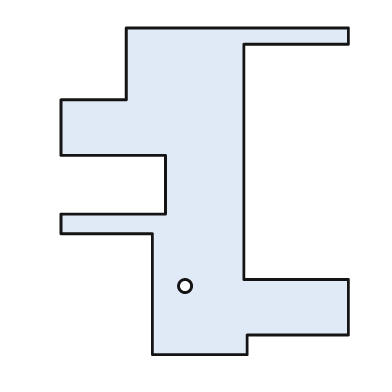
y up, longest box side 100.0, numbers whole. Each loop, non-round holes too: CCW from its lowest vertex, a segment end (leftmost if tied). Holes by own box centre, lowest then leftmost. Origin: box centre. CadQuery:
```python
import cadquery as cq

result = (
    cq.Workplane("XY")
    .moveTo(-16.0, -50.0)
    .lineTo(13.0, -50.0)
    .lineTo(13.0, -44.0)
    .lineTo(44.0, -44.0)
    .lineTo(44.0, -27.0)
    .lineTo(12.0, -27.0)
    .lineTo(12.0, 45.0)
    .lineTo(44.0, 45.0)
    .lineTo(44.0, 50.0)
    .lineTo(-24.0, 50.0)
    .lineTo(-24.0, 28.0)
    .lineTo(-44.0, 28.0)
    .lineTo(-44.0, 11.0)
    .lineTo(-12.0, 11.0)
    .lineTo(-12.0, -7.0)
    .lineTo(-44.0, -7.0)
    .lineTo(-44.0, -13.0)
    .lineTo(-16.0, -13.0)
    .close()
    .moveTo(-6.0, -29.0)
    .circle(2.0)
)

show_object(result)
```